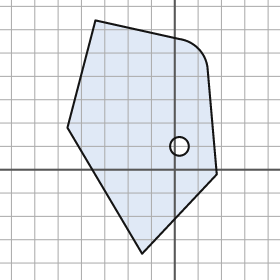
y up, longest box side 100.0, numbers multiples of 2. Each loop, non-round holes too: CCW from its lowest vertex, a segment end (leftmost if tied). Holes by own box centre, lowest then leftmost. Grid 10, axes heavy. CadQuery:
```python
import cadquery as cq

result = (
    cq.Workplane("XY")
    .moveTo(-14.0, -36.0)
    .lineTo(18.0, -2.0)
    .lineTo(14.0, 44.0)
    .threePointArc((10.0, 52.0), (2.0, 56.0))
    .lineTo(-34.0, 64.0)
    .lineTo(-46.0, 18.0)
    .close()
    .moveTo(2.0, 10.0)
    .circle(4.0)
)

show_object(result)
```